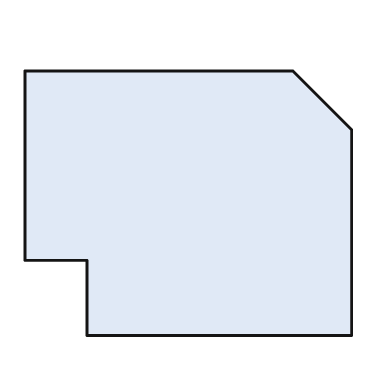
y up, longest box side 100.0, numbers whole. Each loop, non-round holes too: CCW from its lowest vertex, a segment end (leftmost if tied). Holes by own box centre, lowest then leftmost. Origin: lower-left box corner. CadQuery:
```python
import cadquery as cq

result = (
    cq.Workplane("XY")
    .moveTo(19.0, 0.0)
    .lineTo(100.0, 0.0)
    .lineTo(100.0, 63.0)
    .lineTo(82.0, 81.0)
    .lineTo(0.0, 81.0)
    .lineTo(0.0, 23.0)
    .lineTo(19.0, 23.0)
    .close()
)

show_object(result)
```